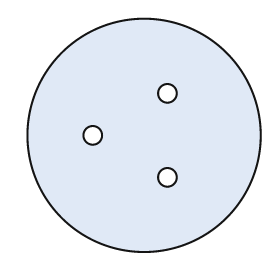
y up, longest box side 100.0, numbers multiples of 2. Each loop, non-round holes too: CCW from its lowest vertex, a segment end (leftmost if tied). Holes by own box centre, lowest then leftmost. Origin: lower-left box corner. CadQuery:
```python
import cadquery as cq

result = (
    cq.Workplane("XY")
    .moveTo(50.0, 50.0)
    .circle(50.0)
    .moveTo(60.0, 32.0)
    .circle(4.0)
    .moveTo(28.0, 50.0)
    .circle(4.0)
    .moveTo(60.0, 68.0)
    .circle(4.0)
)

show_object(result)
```